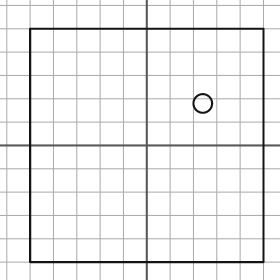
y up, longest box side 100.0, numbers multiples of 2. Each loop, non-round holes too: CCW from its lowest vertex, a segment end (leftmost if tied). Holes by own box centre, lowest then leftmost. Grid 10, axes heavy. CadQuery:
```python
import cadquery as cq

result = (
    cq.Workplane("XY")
    .moveTo(-50.0, -50.0)
    .lineTo(50.0, -50.0)
    .lineTo(50.0, 50.0)
    .lineTo(-50.0, 50.0)
    .close()
    .moveTo(24.0, 18.0)
    .circle(4.0)
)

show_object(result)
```